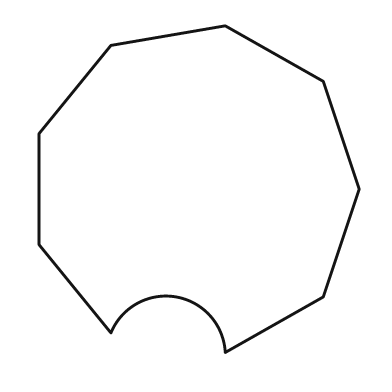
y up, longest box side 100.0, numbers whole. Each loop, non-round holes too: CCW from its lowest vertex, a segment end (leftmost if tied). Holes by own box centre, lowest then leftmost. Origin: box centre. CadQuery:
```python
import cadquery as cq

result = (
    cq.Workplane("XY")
    .moveTo(8.0, -50.0)
    .lineTo(38.0, -33.0)
    .lineTo(49.0, 0.0)
    .lineTo(38.0, 33.0)
    .lineTo(8.0, 50.0)
    .lineTo(-27.0, 44.0)
    .lineTo(-49.0, 17.0)
    .lineTo(-49.0, -17.0)
    .lineTo(-27.0, -44.0)
    .threePointArc((-7.0, -33.0), (8.0, -50.0))
    .close()
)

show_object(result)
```